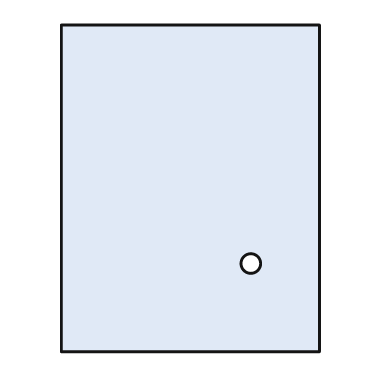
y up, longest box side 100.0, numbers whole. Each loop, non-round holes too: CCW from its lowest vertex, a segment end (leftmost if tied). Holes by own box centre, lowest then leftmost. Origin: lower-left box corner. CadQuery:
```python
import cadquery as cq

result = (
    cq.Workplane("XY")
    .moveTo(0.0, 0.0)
    .lineTo(79.0, 0.0)
    .lineTo(79.0, 100.0)
    .lineTo(0.0, 100.0)
    .close()
    .moveTo(58.0, 27.0)
    .circle(3.0)
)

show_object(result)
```